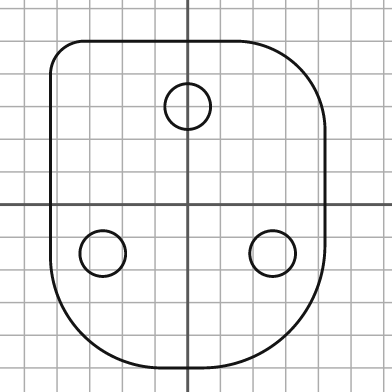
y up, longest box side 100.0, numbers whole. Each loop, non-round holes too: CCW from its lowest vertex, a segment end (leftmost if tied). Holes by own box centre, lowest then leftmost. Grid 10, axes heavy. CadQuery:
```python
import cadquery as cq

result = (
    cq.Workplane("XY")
    .moveTo(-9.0, -50.0)
    .lineTo(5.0, -50.0)
    .threePointArc((31.0, -39.0), (42.0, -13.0))
    .lineTo(42.0, 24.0)
    .threePointArc((34.0, 42.0), (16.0, 50.0))
    .lineTo(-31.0, 50.0)
    .threePointArc((-39.0, 47.0), (-42.0, 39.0))
    .lineTo(-42.0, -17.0)
    .threePointArc((-32.0, -40.0), (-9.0, -50.0))
    .close()
    .moveTo(-26.0, -15.0)
    .circle(7.0)
    .moveTo(26.0, -15.0)
    .circle(7.0)
    .moveTo(0.0, 30.0)
    .circle(7.0)
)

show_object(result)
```